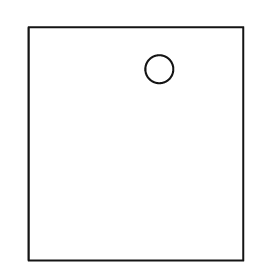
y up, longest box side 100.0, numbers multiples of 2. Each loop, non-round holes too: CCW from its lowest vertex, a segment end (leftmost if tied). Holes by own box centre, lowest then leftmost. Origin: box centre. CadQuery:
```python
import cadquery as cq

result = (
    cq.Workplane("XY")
    .moveTo(-46.0, -50.0)
    .lineTo(46.0, -50.0)
    .lineTo(46.0, 50.0)
    .lineTo(-46.0, 50.0)
    .close()
    .moveTo(10.0, 32.0)
    .circle(6.0)
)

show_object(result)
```